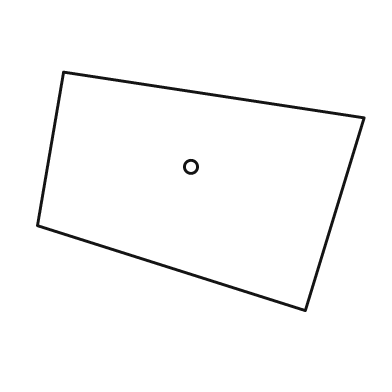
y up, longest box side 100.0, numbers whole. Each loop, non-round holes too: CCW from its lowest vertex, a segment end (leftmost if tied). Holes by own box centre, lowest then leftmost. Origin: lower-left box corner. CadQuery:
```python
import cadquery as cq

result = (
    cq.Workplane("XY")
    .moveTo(82.0, 0.0)
    .lineTo(100.0, 59.0)
    .lineTo(8.0, 73.0)
    .lineTo(0.0, 26.0)
    .close()
    .moveTo(47.0, 44.0)
    .circle(2.0)
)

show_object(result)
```